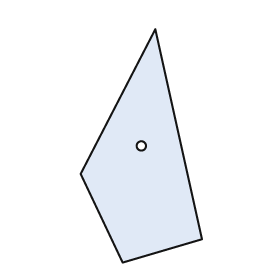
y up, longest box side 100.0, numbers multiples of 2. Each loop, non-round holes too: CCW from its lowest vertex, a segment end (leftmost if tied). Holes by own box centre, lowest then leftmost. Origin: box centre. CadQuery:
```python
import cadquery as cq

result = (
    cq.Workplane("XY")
    .moveTo(-8.0, -50.0)
    .lineTo(26.0, -40.0)
    .lineTo(6.0, 50.0)
    .lineTo(-26.0, -12.0)
    .close()
    .moveTo(0.0, 0.0)
    .circle(2.0)
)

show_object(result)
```